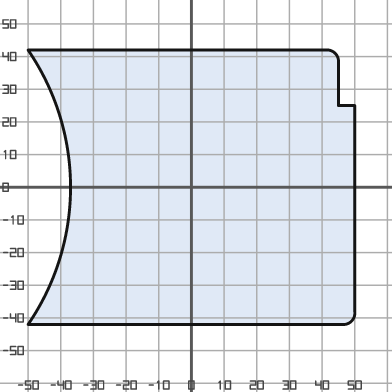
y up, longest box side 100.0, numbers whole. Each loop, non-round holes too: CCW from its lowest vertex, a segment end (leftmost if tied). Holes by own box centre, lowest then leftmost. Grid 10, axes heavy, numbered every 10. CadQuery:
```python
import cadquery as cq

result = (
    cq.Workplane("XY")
    .moveTo(-50.0, -42.0)
    .lineTo(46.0, -42.0)
    .threePointArc((49.0, -41.0), (50.0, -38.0))
    .lineTo(50.0, 25.0)
    .lineTo(45.0, 25.0)
    .lineTo(45.0, 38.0)
    .threePointArc((44.0, 41.0), (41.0, 42.0))
    .lineTo(-50.0, 42.0)
    .threePointArc((-37.0, 0.0), (-50.0, -42.0))
    .close()
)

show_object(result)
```